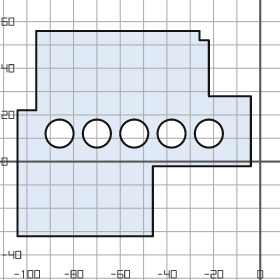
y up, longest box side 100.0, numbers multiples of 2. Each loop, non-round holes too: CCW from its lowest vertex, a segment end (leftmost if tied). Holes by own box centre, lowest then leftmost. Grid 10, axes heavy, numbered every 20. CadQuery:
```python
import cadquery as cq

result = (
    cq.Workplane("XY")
    .moveTo(-104.0, -32.0)
    .lineTo(-46.0, -32.0)
    .lineTo(-46.0, -2.0)
    .lineTo(-4.0, -2.0)
    .lineTo(-4.0, 28.0)
    .lineTo(-22.0, 28.0)
    .lineTo(-22.0, 52.0)
    .lineTo(-26.0, 52.0)
    .lineTo(-26.0, 56.0)
    .lineTo(-96.0, 56.0)
    .lineTo(-96.0, 22.0)
    .lineTo(-104.0, 22.0)
    .close()
    .moveTo(-86.0, 12.0)
    .circle(6.0)
    .moveTo(-70.0, 12.0)
    .circle(6.0)
    .moveTo(-54.0, 12.0)
    .circle(6.0)
    .moveTo(-38.0, 12.0)
    .circle(6.0)
    .moveTo(-22.0, 12.0)
    .circle(6.0)
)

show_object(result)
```